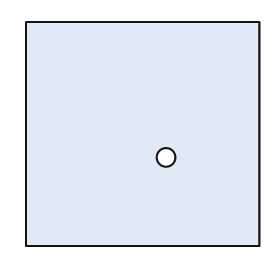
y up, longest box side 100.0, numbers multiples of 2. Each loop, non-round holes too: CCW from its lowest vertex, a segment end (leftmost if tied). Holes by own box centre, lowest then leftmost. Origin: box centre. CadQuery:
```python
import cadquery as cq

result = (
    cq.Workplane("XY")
    .moveTo(-50.0, -48.0)
    .lineTo(50.0, -48.0)
    .lineTo(50.0, 48.0)
    .lineTo(-50.0, 48.0)
    .close()
    .moveTo(10.0, -10.0)
    .circle(4.0)
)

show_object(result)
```